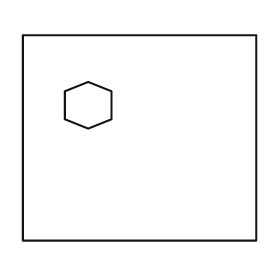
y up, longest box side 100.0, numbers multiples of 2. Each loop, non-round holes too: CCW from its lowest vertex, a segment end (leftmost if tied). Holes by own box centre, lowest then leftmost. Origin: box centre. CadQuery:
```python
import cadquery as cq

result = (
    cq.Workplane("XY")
    .moveTo(-50.0, -44.0)
    .lineTo(50.0, -44.0)
    .lineTo(50.0, 44.0)
    .lineTo(-50.0, 44.0)
    .close()
    .moveTo(-22.0, 4.0)
    .lineTo(-12.0, 8.0)
    .lineTo(-12.0, 20.0)
    .lineTo(-22.0, 24.0)
    .lineTo(-32.0, 20.0)
    .lineTo(-32.0, 8.0)
    .close()
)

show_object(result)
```